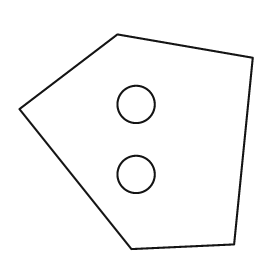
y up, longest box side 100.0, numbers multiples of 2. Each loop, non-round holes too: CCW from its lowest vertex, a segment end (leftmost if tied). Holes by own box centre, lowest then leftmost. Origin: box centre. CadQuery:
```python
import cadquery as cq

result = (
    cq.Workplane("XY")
    .moveTo(-2.0, -46.0)
    .lineTo(42.0, -44.0)
    .lineTo(50.0, 36.0)
    .lineTo(-8.0, 46.0)
    .lineTo(-50.0, 14.0)
    .close()
    .moveTo(0.0, -14.0)
    .circle(8.0)
    .moveTo(0.0, 16.0)
    .circle(8.0)
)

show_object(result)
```